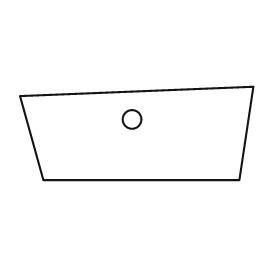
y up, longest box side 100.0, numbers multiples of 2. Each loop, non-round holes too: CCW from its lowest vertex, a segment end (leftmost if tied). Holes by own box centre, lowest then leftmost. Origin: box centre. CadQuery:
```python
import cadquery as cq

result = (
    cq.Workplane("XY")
    .moveTo(-40.0, -20.0)
    .lineTo(44.0, -20.0)
    .lineTo(50.0, 20.0)
    .lineTo(-50.0, 16.0)
    .close()
    .moveTo(-2.0, 6.0)
    .circle(4.0)
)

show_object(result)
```